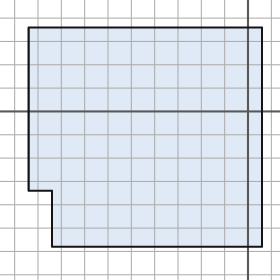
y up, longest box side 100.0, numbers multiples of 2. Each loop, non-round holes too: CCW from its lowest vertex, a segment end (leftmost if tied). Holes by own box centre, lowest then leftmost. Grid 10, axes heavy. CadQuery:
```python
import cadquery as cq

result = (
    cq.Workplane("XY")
    .moveTo(-84.0, -58.0)
    .lineTo(6.0, -58.0)
    .lineTo(6.0, 36.0)
    .lineTo(-94.0, 36.0)
    .lineTo(-94.0, -34.0)
    .lineTo(-84.0, -34.0)
    .close()
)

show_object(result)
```